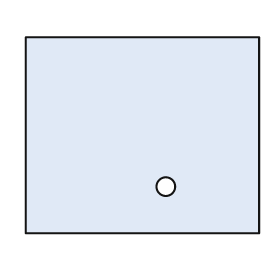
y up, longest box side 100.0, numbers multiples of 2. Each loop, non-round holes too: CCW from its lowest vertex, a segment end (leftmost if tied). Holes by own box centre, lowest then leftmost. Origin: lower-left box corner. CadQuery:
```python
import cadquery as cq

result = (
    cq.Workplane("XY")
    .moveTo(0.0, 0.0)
    .lineTo(100.0, 0.0)
    .lineTo(100.0, 84.0)
    .lineTo(0.0, 84.0)
    .close()
    .moveTo(60.0, 20.0)
    .circle(4.0)
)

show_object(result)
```